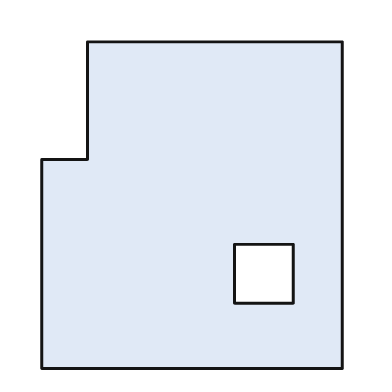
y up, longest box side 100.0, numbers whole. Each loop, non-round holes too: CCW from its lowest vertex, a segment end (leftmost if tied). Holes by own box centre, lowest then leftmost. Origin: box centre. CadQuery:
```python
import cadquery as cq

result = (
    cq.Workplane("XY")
    .moveTo(-46.0, -50.0)
    .lineTo(46.0, -50.0)
    .lineTo(46.0, 50.0)
    .lineTo(-32.0, 50.0)
    .lineTo(-32.0, 14.0)
    .lineTo(-46.0, 14.0)
    .close()
    .moveTo(13.0, -30.0)
    .lineTo(31.0, -30.0)
    .lineTo(31.0, -12.0)
    .lineTo(13.0, -12.0)
    .close()
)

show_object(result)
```